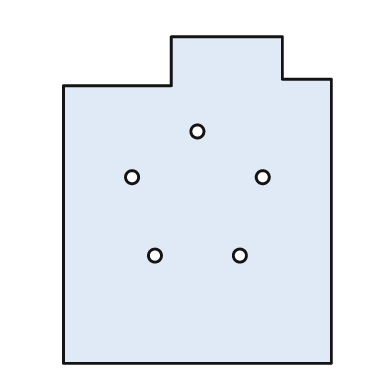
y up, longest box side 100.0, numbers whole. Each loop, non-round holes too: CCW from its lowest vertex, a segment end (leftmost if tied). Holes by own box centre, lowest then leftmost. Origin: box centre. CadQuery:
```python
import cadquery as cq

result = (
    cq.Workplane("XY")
    .moveTo(-41.0, -50.0)
    .lineTo(41.0, -50.0)
    .lineTo(41.0, 37.0)
    .lineTo(26.0, 37.0)
    .lineTo(26.0, 50.0)
    .lineTo(-8.0, 50.0)
    .lineTo(-8.0, 35.0)
    .lineTo(-41.0, 35.0)
    .close()
    .moveTo(-13.0, -17.0)
    .circle(2.0)
    .moveTo(13.0, -17.0)
    .circle(2.0)
    .moveTo(-20.0, 7.0)
    .circle(2.0)
    .moveTo(20.0, 7.0)
    .circle(2.0)
    .moveTo(0.0, 21.0)
    .circle(2.0)
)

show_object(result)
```